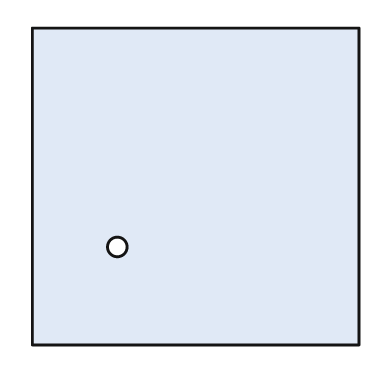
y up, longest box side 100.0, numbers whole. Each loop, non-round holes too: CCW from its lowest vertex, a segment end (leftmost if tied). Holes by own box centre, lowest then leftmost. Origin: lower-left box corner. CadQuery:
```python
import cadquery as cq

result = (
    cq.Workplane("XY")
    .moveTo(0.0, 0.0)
    .lineTo(100.0, 0.0)
    .lineTo(100.0, 97.0)
    .lineTo(0.0, 97.0)
    .close()
    .moveTo(26.0, 30.0)
    .circle(3.0)
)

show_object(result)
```